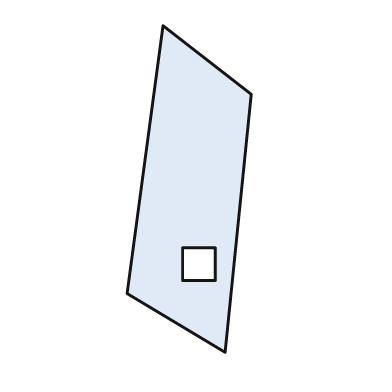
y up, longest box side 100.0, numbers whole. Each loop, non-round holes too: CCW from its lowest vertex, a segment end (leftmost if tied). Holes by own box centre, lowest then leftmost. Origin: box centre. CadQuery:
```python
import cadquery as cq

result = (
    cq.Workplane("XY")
    .moveTo(11.0, -50.0)
    .lineTo(19.0, 29.0)
    .lineTo(-8.0, 50.0)
    .lineTo(-19.0, -32.0)
    .close()
    .moveTo(-2.0, -28.0)
    .lineTo(8.0, -28.0)
    .lineTo(8.0, -18.0)
    .lineTo(-2.0, -18.0)
    .close()
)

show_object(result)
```